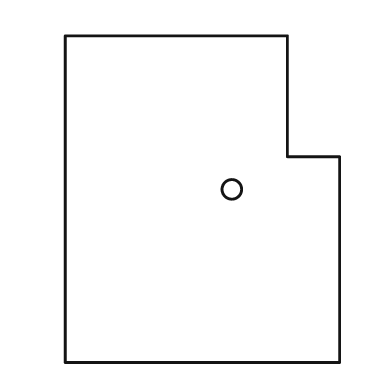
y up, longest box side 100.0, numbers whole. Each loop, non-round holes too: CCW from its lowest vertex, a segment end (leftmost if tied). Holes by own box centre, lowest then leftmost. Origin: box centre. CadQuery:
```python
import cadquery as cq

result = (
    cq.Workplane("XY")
    .moveTo(-42.0, -50.0)
    .lineTo(42.0, -50.0)
    .lineTo(42.0, 13.0)
    .lineTo(26.0, 13.0)
    .lineTo(26.0, 50.0)
    .lineTo(-42.0, 50.0)
    .close()
    .moveTo(9.0, 3.0)
    .circle(3.0)
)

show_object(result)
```